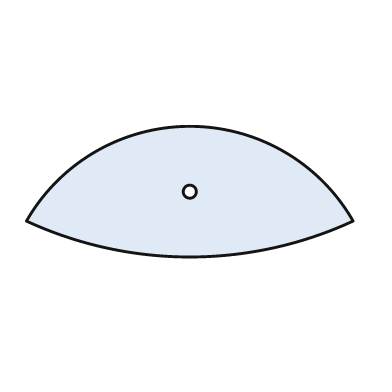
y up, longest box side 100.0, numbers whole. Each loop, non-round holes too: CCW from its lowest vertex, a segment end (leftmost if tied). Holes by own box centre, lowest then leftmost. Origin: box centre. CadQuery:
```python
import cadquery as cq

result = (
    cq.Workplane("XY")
    .moveTo(-50.0, -9.0)
    .threePointArc((0.0, -20.0), (50.0, -9.0))
    .threePointArc((0.0, 20.0), (-50.0, -9.0))
    .close()
    .moveTo(0.0, 0.0)
    .circle(2.0)
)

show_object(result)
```